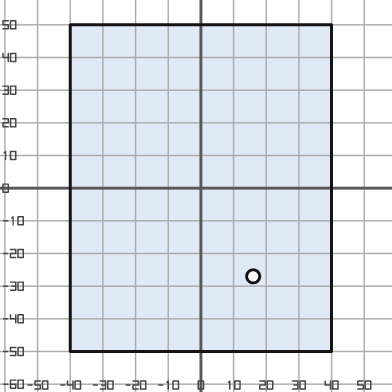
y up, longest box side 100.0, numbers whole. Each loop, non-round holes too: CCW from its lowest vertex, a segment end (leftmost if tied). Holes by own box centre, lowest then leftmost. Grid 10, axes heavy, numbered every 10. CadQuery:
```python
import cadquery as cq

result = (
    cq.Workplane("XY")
    .moveTo(-40.0, -50.0)
    .lineTo(40.0, -50.0)
    .lineTo(40.0, 50.0)
    .lineTo(-40.0, 50.0)
    .close()
    .moveTo(16.0, -27.0)
    .circle(2.0)
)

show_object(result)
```